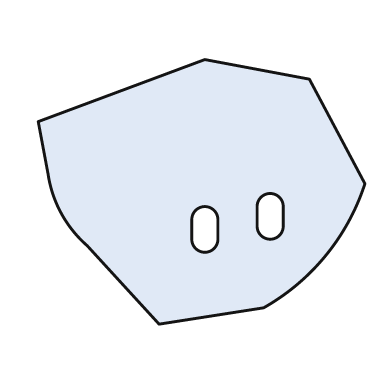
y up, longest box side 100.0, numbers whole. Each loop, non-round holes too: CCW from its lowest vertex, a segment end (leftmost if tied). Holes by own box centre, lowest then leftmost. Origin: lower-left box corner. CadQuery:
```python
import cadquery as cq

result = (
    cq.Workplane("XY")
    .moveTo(37.0, 0.0)
    .lineTo(69.0, 5.0)
    .threePointArc((88.0, 21.0), (100.0, 43.0))
    .lineTo(83.0, 75.0)
    .lineTo(51.0, 81.0)
    .lineTo(0.0, 62.0)
    .lineTo(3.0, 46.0)
    .threePointArc((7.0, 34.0), (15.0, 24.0))
    .close()
    .moveTo(47.0, 26.0)
    .threePointArc((51.0, 22.0), (55.0, 26.0))
    .lineTo(55.0, 32.0)
    .threePointArc((51.0, 36.0), (47.0, 32.0))
    .close()
    .moveTo(67.0, 30.0)
    .threePointArc((71.0, 26.0), (75.0, 30.0))
    .lineTo(75.0, 36.0)
    .threePointArc((71.0, 40.0), (67.0, 36.0))
    .close()
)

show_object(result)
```